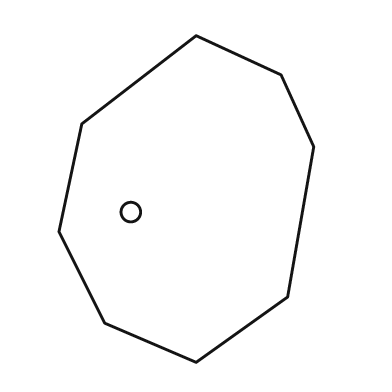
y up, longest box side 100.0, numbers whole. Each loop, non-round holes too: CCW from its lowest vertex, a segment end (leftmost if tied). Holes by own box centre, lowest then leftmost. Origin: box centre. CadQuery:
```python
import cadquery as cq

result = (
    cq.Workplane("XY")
    .moveTo(3.0, -50.0)
    .lineTo(31.0, -30.0)
    .lineTo(39.0, 16.0)
    .lineTo(29.0, 38.0)
    .lineTo(3.0, 50.0)
    .lineTo(-32.0, 23.0)
    .lineTo(-39.0, -10.0)
    .lineTo(-25.0, -38.0)
    .close()
    .moveTo(-17.0, -4.0)
    .circle(3.0)
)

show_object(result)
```